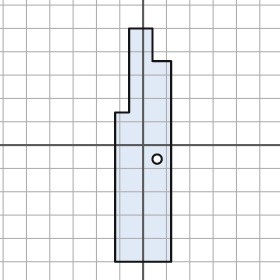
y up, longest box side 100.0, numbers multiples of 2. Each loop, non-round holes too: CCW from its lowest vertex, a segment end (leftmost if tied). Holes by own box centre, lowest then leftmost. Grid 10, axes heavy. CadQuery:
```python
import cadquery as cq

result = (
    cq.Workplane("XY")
    .moveTo(-12.0, -50.0)
    .lineTo(12.0, -50.0)
    .lineTo(12.0, 36.0)
    .lineTo(4.0, 36.0)
    .lineTo(4.0, 50.0)
    .lineTo(-6.0, 50.0)
    .lineTo(-6.0, 14.0)
    .lineTo(-12.0, 14.0)
    .close()
    .moveTo(6.0, -6.0)
    .circle(2.0)
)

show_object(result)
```